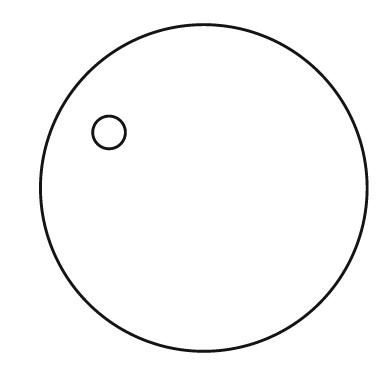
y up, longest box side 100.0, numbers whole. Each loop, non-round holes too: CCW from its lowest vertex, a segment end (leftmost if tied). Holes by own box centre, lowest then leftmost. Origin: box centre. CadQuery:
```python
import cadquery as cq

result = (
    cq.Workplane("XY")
    .moveTo(0.0, 0.0)
    .circle(50.0)
    .moveTo(-29.0, 17.0)
    .circle(5.0)
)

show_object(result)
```